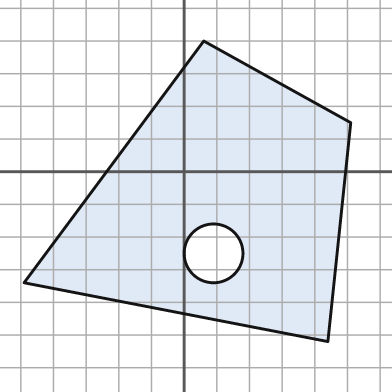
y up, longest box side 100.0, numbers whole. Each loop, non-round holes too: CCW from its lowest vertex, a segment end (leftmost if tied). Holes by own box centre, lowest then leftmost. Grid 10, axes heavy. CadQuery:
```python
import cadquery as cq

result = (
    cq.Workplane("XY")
    .moveTo(44.0, -52.0)
    .lineTo(51.0, 15.0)
    .lineTo(6.0, 40.0)
    .lineTo(-49.0, -34.0)
    .close()
    .moveTo(9.0, -25.0)
    .circle(9.0)
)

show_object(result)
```